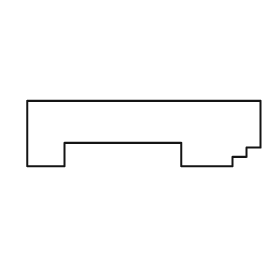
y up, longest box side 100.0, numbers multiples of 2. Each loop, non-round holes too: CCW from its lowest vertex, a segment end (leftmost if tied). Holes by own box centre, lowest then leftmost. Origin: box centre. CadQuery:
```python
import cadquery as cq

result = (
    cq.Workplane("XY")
    .moveTo(-50.0, -14.0)
    .lineTo(-34.0, -14.0)
    .lineTo(-34.0, -4.0)
    .lineTo(16.0, -4.0)
    .lineTo(16.0, -14.0)
    .lineTo(38.0, -14.0)
    .lineTo(38.0, -10.0)
    .lineTo(44.0, -10.0)
    .lineTo(44.0, -6.0)
    .lineTo(50.0, -6.0)
    .lineTo(50.0, 14.0)
    .lineTo(-50.0, 14.0)
    .close()
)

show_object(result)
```